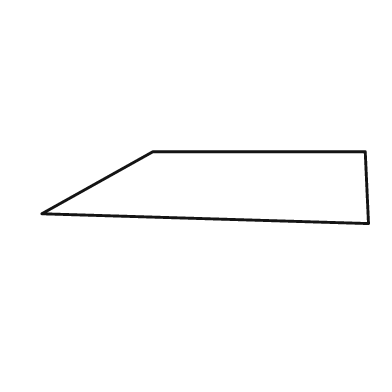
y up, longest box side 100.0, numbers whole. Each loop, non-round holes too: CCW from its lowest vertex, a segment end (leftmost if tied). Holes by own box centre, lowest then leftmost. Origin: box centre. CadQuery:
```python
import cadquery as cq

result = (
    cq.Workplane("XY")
    .moveTo(50.0, -11.0)
    .lineTo(49.0, 11.0)
    .lineTo(-16.0, 11.0)
    .lineTo(-50.0, -8.0)
    .close()
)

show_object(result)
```